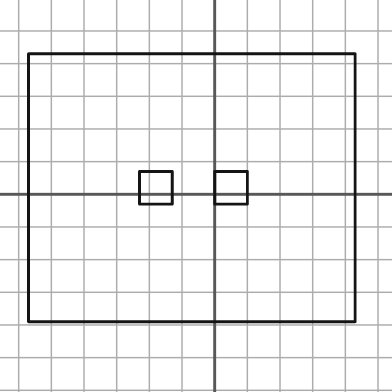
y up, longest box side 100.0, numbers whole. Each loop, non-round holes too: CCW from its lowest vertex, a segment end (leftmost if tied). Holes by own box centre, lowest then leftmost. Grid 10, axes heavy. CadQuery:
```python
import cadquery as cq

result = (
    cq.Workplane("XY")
    .moveTo(-57.0, -39.0)
    .lineTo(43.0, -39.0)
    .lineTo(43.0, 43.0)
    .lineTo(-57.0, 43.0)
    .close()
    .moveTo(-23.0, -3.0)
    .lineTo(-13.0, -3.0)
    .lineTo(-13.0, 7.0)
    .lineTo(-23.0, 7.0)
    .close()
    .moveTo(0.0, -3.0)
    .lineTo(10.0, -3.0)
    .lineTo(10.0, 7.0)
    .lineTo(0.0, 7.0)
    .close()
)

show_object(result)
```